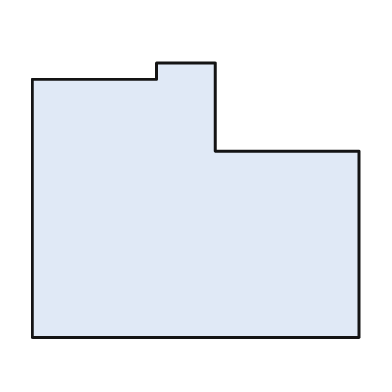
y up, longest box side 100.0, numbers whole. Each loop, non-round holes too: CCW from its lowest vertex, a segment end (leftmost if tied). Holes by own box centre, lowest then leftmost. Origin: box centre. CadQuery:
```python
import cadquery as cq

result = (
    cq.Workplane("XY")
    .moveTo(-50.0, -42.0)
    .lineTo(50.0, -42.0)
    .lineTo(50.0, 15.0)
    .lineTo(6.0, 15.0)
    .lineTo(6.0, 42.0)
    .lineTo(-12.0, 42.0)
    .lineTo(-12.0, 37.0)
    .lineTo(-50.0, 37.0)
    .close()
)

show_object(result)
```